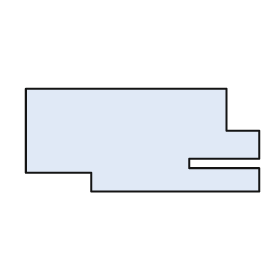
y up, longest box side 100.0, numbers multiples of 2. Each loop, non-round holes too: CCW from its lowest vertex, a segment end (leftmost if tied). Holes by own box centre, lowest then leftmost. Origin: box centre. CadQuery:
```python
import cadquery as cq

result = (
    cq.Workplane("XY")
    .moveTo(-22.0, -22.0)
    .lineTo(50.0, -22.0)
    .lineTo(50.0, -12.0)
    .lineTo(20.0, -12.0)
    .lineTo(20.0, -8.0)
    .lineTo(50.0, -8.0)
    .lineTo(50.0, 4.0)
    .lineTo(36.0, 4.0)
    .lineTo(36.0, 22.0)
    .lineTo(-50.0, 22.0)
    .lineTo(-50.0, -14.0)
    .lineTo(-22.0, -14.0)
    .close()
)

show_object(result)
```